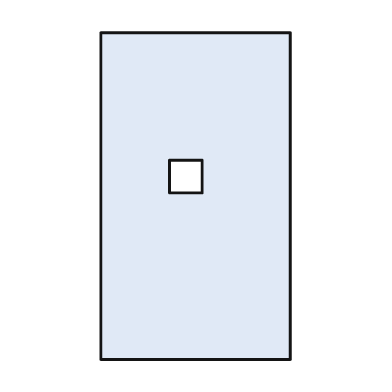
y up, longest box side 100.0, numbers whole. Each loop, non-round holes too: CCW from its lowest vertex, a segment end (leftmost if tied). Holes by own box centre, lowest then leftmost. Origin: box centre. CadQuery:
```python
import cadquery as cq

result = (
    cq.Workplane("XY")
    .moveTo(-29.0, -50.0)
    .lineTo(29.0, -50.0)
    .lineTo(29.0, 50.0)
    .lineTo(-29.0, 50.0)
    .close()
    .moveTo(-8.0, 1.0)
    .lineTo(2.0, 1.0)
    .lineTo(2.0, 11.0)
    .lineTo(-8.0, 11.0)
    .close()
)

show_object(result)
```